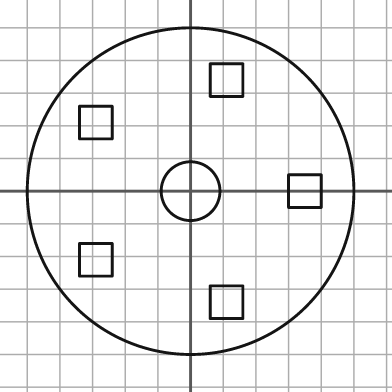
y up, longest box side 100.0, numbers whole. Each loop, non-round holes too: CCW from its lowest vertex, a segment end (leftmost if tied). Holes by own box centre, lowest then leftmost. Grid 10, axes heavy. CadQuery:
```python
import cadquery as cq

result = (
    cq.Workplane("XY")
    .moveTo(0.0, 0.0)
    .circle(50.0)
    .moveTo(6.0, -39.0)
    .lineTo(16.0, -39.0)
    .lineTo(16.0, -29.0)
    .lineTo(6.0, -29.0)
    .close()
    .moveTo(-34.0, -26.0)
    .lineTo(-24.0, -26.0)
    .lineTo(-24.0, -16.0)
    .lineTo(-34.0, -16.0)
    .close()
    .moveTo(0.0, 0.0)
    .circle(9.0)
    .moveTo(30.0, -5.0)
    .lineTo(40.0, -5.0)
    .lineTo(40.0, 5.0)
    .lineTo(30.0, 5.0)
    .close()
    .moveTo(-34.0, 16.0)
    .lineTo(-24.0, 16.0)
    .lineTo(-24.0, 26.0)
    .lineTo(-34.0, 26.0)
    .close()
    .moveTo(6.0, 29.0)
    .lineTo(16.0, 29.0)
    .lineTo(16.0, 39.0)
    .lineTo(6.0, 39.0)
    .close()
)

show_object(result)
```